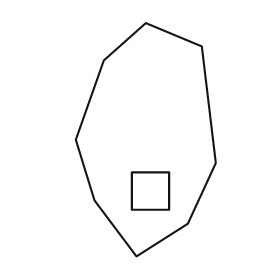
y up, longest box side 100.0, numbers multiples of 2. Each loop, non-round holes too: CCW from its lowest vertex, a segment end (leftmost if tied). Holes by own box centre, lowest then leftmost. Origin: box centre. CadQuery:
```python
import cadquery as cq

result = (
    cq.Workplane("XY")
    .moveTo(-4.0, -50.0)
    .lineTo(18.0, -36.0)
    .lineTo(30.0, -10.0)
    .lineTo(24.0, 40.0)
    .lineTo(0.0, 50.0)
    .lineTo(-18.0, 34.0)
    .lineTo(-30.0, 0.0)
    .lineTo(-22.0, -26.0)
    .close()
    .moveTo(-6.0, -30.0)
    .lineTo(10.0, -30.0)
    .lineTo(10.0, -14.0)
    .lineTo(-6.0, -14.0)
    .close()
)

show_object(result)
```